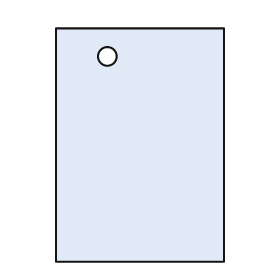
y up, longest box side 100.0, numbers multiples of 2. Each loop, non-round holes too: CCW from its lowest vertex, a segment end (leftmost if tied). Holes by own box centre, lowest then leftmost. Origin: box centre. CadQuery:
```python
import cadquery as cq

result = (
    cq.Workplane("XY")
    .moveTo(-36.0, -50.0)
    .lineTo(36.0, -50.0)
    .lineTo(36.0, 50.0)
    .lineTo(-36.0, 50.0)
    .close()
    .moveTo(-14.0, 38.0)
    .circle(4.0)
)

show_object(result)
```